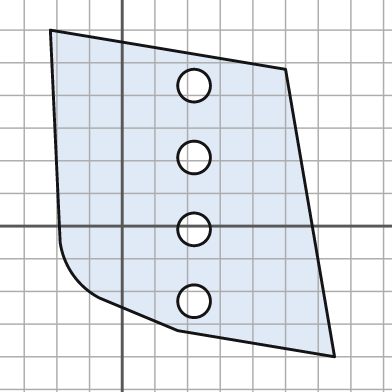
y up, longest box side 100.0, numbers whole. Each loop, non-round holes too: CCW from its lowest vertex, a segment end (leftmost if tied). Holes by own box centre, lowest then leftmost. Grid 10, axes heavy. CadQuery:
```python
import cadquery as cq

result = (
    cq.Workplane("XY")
    .moveTo(65.0, -40.0)
    .lineTo(50.0, 48.0)
    .lineTo(-22.0, 60.0)
    .lineTo(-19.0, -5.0)
    .threePointArc((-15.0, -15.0), (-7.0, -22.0))
    .lineTo(17.0, -32.0)
    .close()
    .moveTo(22.0, -23.0)
    .circle(5.0)
    .moveTo(22.0, -1.0)
    .circle(5.0)
    .moveTo(22.0, 21.0)
    .circle(5.0)
    .moveTo(22.0, 43.0)
    .circle(5.0)
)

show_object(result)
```